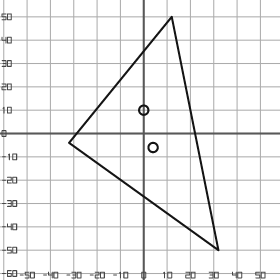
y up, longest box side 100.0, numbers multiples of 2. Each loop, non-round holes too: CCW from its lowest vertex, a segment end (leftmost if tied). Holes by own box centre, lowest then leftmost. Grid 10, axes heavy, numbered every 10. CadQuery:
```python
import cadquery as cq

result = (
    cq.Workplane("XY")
    .moveTo(32.0, -50.0)
    .lineTo(12.0, 50.0)
    .lineTo(-32.0, -4.0)
    .close()
    .moveTo(4.0, -6.0)
    .circle(2.0)
    .moveTo(0.0, 10.0)
    .circle(2.0)
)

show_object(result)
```